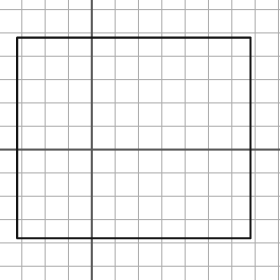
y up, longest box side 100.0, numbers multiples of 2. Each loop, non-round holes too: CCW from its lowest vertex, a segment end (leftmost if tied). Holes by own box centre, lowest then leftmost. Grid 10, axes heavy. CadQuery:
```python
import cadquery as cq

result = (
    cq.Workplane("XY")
    .moveTo(-32.0, -38.0)
    .lineTo(68.0, -38.0)
    .lineTo(68.0, 48.0)
    .lineTo(-32.0, 48.0)
    .close()
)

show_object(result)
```